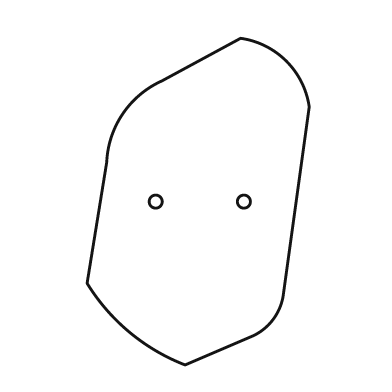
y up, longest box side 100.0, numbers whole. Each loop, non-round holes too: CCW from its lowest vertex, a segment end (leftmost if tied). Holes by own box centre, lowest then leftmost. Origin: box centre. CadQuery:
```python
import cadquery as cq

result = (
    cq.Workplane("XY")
    .moveTo(-4.0, -50.0)
    .lineTo(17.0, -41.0)
    .threePointArc((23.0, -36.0), (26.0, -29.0))
    .lineTo(34.0, 29.0)
    .threePointArc((27.0, 43.0), (13.0, 50.0))
    .lineTo(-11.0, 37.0)
    .threePointArc((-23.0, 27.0), (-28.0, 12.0))
    .lineTo(-34.0, -25.0)
    .threePointArc((-21.0, -40.0), (-4.0, -50.0))
    .close()
    .moveTo(-13.0, 0.0)
    .circle(2.0)
    .moveTo(14.0, 0.0)
    .circle(2.0)
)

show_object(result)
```